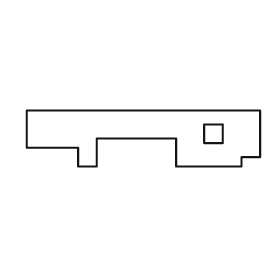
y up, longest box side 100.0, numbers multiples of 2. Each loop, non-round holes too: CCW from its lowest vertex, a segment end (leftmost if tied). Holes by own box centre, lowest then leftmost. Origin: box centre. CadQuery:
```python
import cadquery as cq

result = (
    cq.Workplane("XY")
    .moveTo(-28.0, -12.0)
    .lineTo(-20.0, -12.0)
    .lineTo(-20.0, 0.0)
    .lineTo(14.0, 0.0)
    .lineTo(14.0, -12.0)
    .lineTo(42.0, -12.0)
    .lineTo(42.0, -8.0)
    .lineTo(50.0, -8.0)
    .lineTo(50.0, 12.0)
    .lineTo(-50.0, 12.0)
    .lineTo(-50.0, -4.0)
    .lineTo(-28.0, -4.0)
    .close()
    .moveTo(26.0, -2.0)
    .lineTo(34.0, -2.0)
    .lineTo(34.0, 6.0)
    .lineTo(26.0, 6.0)
    .close()
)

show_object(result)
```